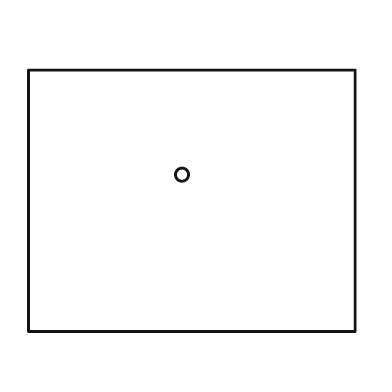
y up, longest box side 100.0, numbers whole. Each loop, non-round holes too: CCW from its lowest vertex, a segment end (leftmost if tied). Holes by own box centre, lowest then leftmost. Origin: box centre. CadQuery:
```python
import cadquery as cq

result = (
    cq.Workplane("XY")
    .moveTo(-50.0, -40.0)
    .lineTo(50.0, -40.0)
    .lineTo(50.0, 40.0)
    .lineTo(-50.0, 40.0)
    .close()
    .moveTo(-3.0, 8.0)
    .circle(2.0)
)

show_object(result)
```